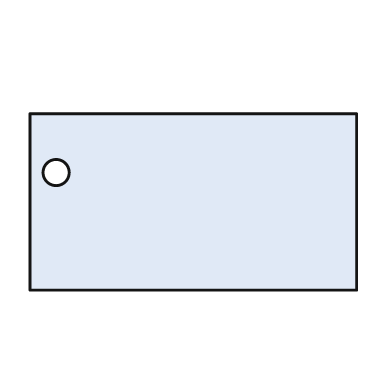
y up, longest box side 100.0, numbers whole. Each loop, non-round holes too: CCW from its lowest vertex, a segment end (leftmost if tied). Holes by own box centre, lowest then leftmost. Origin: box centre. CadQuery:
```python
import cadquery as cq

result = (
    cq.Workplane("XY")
    .moveTo(-50.0, -27.0)
    .lineTo(50.0, -27.0)
    .lineTo(50.0, 27.0)
    .lineTo(-50.0, 27.0)
    .close()
    .moveTo(-42.0, 9.0)
    .circle(4.0)
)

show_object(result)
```